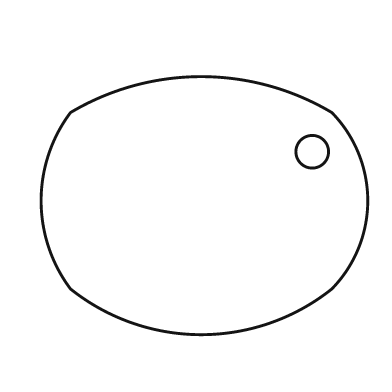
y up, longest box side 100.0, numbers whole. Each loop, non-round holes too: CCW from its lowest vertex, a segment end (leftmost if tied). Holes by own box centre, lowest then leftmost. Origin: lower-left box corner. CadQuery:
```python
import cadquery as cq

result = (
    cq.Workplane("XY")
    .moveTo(9.0, 14.0)
    .threePointArc((49.0, 0.0), (89.0, 14.0))
    .threePointArc((100.0, 41.0), (89.0, 68.0))
    .threePointArc((49.0, 79.0), (9.0, 68.0))
    .threePointArc((0.0, 41.0), (9.0, 14.0))
    .close()
    .moveTo(83.0, 56.0)
    .circle(5.0)
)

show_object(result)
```